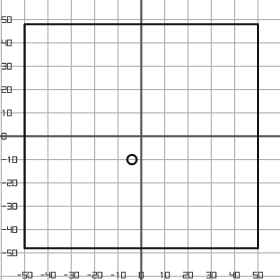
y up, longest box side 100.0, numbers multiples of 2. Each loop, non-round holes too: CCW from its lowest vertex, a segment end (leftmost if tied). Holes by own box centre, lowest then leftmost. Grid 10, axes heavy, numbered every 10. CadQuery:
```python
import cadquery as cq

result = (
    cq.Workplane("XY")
    .moveTo(-50.0, -48.0)
    .lineTo(50.0, -48.0)
    .lineTo(50.0, 48.0)
    .lineTo(-50.0, 48.0)
    .close()
    .moveTo(-4.0, -10.0)
    .circle(2.0)
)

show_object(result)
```